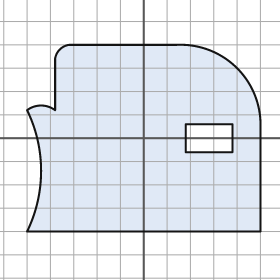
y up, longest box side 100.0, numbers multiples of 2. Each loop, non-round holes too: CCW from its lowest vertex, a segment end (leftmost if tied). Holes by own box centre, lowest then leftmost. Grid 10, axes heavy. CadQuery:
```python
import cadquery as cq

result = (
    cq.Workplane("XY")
    .moveTo(-50.0, -40.0)
    .lineTo(50.0, -40.0)
    .lineTo(50.0, 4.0)
    .threePointArc((40.0, 30.0), (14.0, 40.0))
    .lineTo(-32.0, 40.0)
    .threePointArc((-36.0, 38.0), (-38.0, 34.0))
    .lineTo(-38.0, 12.0)
    .threePointArc((-44.0, 14.0), (-50.0, 12.0))
    .threePointArc((-44.0, -14.0), (-50.0, -40.0))
    .close()
    .moveTo(18.0, -6.0)
    .lineTo(38.0, -6.0)
    .lineTo(38.0, 6.0)
    .lineTo(18.0, 6.0)
    .close()
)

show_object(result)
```